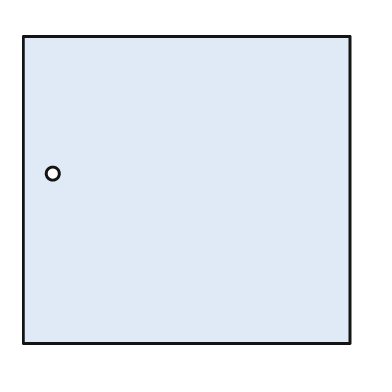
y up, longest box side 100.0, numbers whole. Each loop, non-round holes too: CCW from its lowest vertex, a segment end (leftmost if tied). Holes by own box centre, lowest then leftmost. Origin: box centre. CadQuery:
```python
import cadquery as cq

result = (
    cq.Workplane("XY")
    .moveTo(-50.0, -47.0)
    .lineTo(50.0, -47.0)
    .lineTo(50.0, 47.0)
    .lineTo(-50.0, 47.0)
    .close()
    .moveTo(-41.0, 5.0)
    .circle(2.0)
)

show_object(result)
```